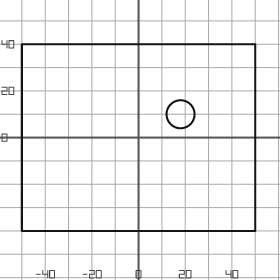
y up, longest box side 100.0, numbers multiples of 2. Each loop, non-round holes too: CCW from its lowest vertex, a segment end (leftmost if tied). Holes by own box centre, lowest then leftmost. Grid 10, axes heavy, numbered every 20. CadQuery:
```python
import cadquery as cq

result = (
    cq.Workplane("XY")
    .moveTo(-50.0, -40.0)
    .lineTo(50.0, -40.0)
    .lineTo(50.0, 40.0)
    .lineTo(-50.0, 40.0)
    .close()
    .moveTo(18.0, 10.0)
    .circle(6.0)
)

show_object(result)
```